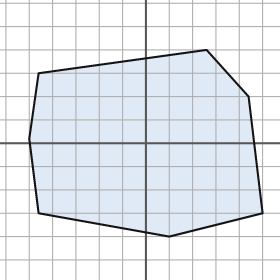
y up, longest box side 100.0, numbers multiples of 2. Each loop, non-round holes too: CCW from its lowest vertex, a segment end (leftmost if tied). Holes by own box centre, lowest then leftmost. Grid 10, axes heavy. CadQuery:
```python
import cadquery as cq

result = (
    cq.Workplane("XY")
    .moveTo(10.0, -40.0)
    .lineTo(50.0, -30.0)
    .lineTo(44.0, 20.0)
    .lineTo(26.0, 40.0)
    .lineTo(-46.0, 30.0)
    .lineTo(-50.0, 2.0)
    .lineTo(-46.0, -30.0)
    .close()
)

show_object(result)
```